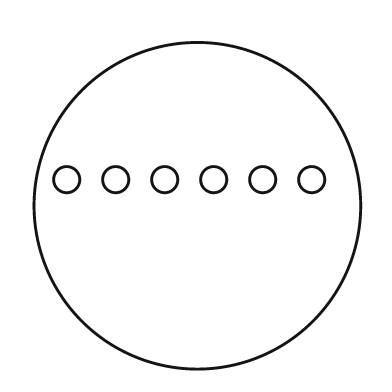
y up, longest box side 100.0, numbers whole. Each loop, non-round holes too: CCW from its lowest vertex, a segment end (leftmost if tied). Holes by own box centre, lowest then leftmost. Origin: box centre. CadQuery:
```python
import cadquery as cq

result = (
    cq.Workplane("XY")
    .moveTo(0.0, 0.0)
    .circle(50.0)
    .moveTo(-40.0, 8.0)
    .circle(4.0)
    .moveTo(-25.0, 8.0)
    .circle(4.0)
    .moveTo(-10.0, 8.0)
    .circle(4.0)
    .moveTo(5.0, 8.0)
    .circle(4.0)
    .moveTo(20.0, 8.0)
    .circle(4.0)
    .moveTo(35.0, 8.0)
    .circle(4.0)
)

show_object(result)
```